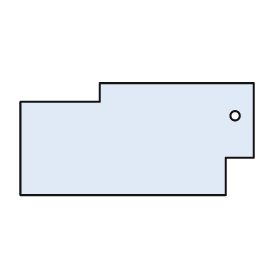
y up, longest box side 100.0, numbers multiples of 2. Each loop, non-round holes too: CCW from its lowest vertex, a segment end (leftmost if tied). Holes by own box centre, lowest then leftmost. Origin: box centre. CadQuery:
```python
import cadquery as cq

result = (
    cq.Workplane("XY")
    .moveTo(-50.0, -24.0)
    .lineTo(38.0, -24.0)
    .lineTo(38.0, -8.0)
    .lineTo(50.0, -8.0)
    .lineTo(50.0, 24.0)
    .lineTo(-16.0, 24.0)
    .lineTo(-16.0, 16.0)
    .lineTo(-50.0, 16.0)
    .close()
    .moveTo(42.0, 10.0)
    .circle(2.0)
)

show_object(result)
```